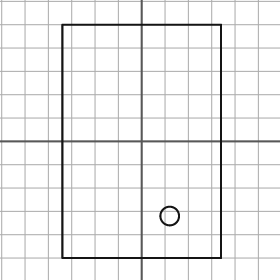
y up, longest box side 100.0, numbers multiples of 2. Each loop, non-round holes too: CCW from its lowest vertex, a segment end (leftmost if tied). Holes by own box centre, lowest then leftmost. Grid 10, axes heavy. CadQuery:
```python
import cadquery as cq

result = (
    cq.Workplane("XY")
    .moveTo(-34.0, -50.0)
    .lineTo(34.0, -50.0)
    .lineTo(34.0, 50.0)
    .lineTo(-34.0, 50.0)
    .close()
    .moveTo(12.0, -32.0)
    .circle(4.0)
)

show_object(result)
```